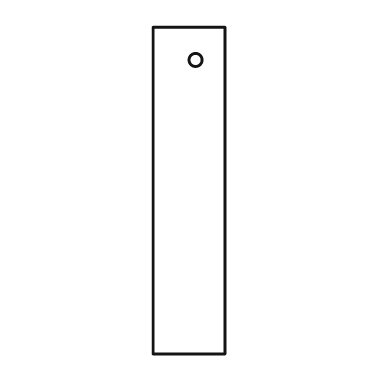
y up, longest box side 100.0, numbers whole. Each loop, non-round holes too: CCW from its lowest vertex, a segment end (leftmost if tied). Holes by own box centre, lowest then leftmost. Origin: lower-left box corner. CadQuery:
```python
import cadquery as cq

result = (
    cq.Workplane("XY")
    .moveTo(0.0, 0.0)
    .lineTo(22.0, 0.0)
    .lineTo(22.0, 100.0)
    .lineTo(0.0, 100.0)
    .close()
    .moveTo(13.0, 90.0)
    .circle(2.0)
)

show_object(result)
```